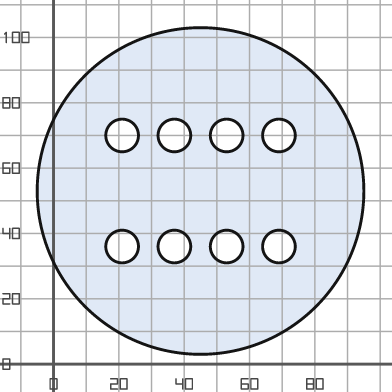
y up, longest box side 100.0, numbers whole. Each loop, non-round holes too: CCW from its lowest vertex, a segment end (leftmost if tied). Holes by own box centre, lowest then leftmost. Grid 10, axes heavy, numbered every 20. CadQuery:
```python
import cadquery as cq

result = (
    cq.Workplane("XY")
    .moveTo(45.0, 53.0)
    .circle(50.0)
    .moveTo(21.0, 36.0)
    .circle(5.0)
    .moveTo(37.0, 36.0)
    .circle(5.0)
    .moveTo(53.0, 36.0)
    .circle(5.0)
    .moveTo(69.0, 36.0)
    .circle(5.0)
    .moveTo(21.0, 70.0)
    .circle(5.0)
    .moveTo(37.0, 70.0)
    .circle(5.0)
    .moveTo(53.0, 70.0)
    .circle(5.0)
    .moveTo(69.0, 70.0)
    .circle(5.0)
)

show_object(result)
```